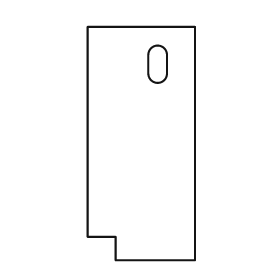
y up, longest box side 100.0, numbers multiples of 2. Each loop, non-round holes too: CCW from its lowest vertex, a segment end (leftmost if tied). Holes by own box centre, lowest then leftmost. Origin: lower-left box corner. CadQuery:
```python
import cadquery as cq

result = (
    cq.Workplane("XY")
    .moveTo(12.0, 0.0)
    .lineTo(46.0, 0.0)
    .lineTo(46.0, 100.0)
    .lineTo(0.0, 100.0)
    .lineTo(0.0, 10.0)
    .lineTo(12.0, 10.0)
    .close()
    .moveTo(26.0, 80.0)
    .threePointArc((30.0, 76.0), (34.0, 80.0))
    .lineTo(34.0, 88.0)
    .threePointArc((30.0, 92.0), (26.0, 88.0))
    .close()
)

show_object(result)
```